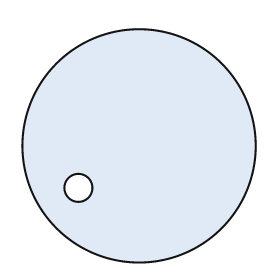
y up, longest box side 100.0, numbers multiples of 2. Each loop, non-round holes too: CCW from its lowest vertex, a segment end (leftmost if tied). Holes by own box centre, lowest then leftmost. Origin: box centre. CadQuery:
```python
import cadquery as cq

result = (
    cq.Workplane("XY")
    .moveTo(0.0, 0.0)
    .circle(50.0)
    .moveTo(-26.0, -18.0)
    .circle(6.0)
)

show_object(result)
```